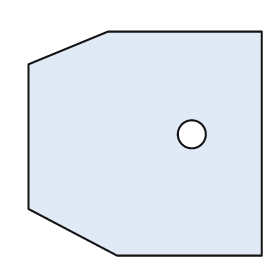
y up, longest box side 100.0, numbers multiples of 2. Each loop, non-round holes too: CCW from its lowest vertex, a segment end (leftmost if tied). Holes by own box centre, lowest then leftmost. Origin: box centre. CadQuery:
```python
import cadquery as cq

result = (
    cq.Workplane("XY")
    .moveTo(-12.0, -48.0)
    .lineTo(50.0, -48.0)
    .lineTo(50.0, 48.0)
    .lineTo(-16.0, 48.0)
    .lineTo(-50.0, 34.0)
    .lineTo(-50.0, -28.0)
    .close()
    .moveTo(20.0, 4.0)
    .circle(6.0)
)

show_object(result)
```